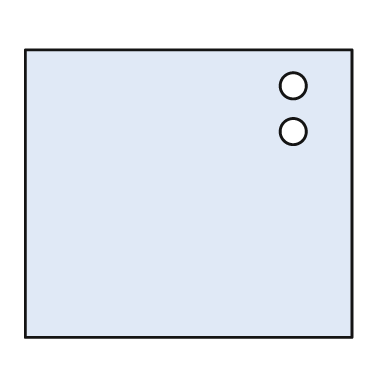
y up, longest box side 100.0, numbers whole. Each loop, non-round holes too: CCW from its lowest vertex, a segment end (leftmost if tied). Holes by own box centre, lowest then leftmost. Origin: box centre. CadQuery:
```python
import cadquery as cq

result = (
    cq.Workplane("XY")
    .moveTo(-50.0, -44.0)
    .lineTo(50.0, -44.0)
    .lineTo(50.0, 44.0)
    .lineTo(-50.0, 44.0)
    .close()
    .moveTo(32.0, 19.0)
    .circle(4.0)
    .moveTo(32.0, 33.0)
    .circle(4.0)
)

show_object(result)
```